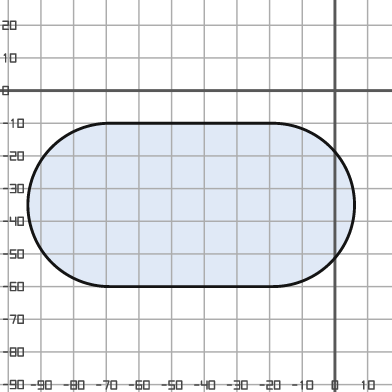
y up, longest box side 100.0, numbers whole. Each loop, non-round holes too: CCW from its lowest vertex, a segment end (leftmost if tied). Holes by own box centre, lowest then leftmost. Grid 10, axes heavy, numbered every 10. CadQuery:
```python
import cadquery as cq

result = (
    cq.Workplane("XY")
    .moveTo(-69.0, -60.0)
    .lineTo(-19.0, -60.0)
    .threePointArc((6.0, -35.0), (-19.0, -10.0))
    .lineTo(-69.0, -10.0)
    .threePointArc((-94.0, -35.0), (-69.0, -60.0))
    .close()
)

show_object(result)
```